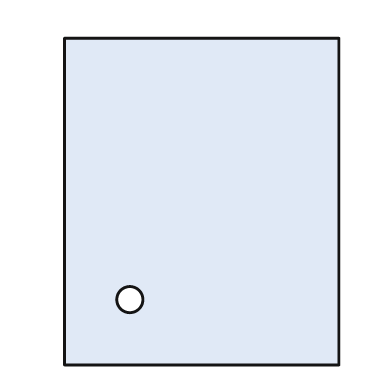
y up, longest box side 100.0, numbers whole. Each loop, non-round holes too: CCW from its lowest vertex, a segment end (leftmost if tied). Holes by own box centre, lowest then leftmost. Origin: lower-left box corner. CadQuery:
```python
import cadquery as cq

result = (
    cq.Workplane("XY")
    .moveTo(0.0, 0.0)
    .lineTo(84.0, 0.0)
    .lineTo(84.0, 100.0)
    .lineTo(0.0, 100.0)
    .close()
    .moveTo(20.0, 20.0)
    .circle(4.0)
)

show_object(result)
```